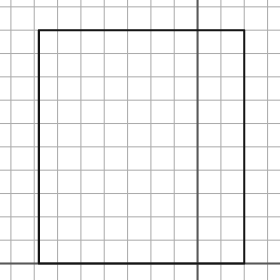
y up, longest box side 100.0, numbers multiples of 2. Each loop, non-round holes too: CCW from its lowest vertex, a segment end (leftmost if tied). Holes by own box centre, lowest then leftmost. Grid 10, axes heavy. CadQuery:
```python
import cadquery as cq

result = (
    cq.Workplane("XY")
    .moveTo(-68.0, 0.0)
    .lineTo(20.0, 0.0)
    .lineTo(20.0, 100.0)
    .lineTo(-68.0, 100.0)
    .close()
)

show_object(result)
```